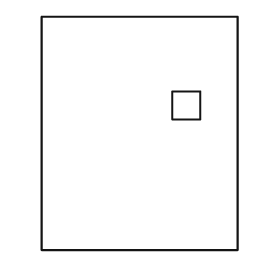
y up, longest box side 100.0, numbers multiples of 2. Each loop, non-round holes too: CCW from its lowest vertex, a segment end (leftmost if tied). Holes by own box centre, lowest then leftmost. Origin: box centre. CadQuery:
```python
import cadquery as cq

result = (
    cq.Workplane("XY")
    .moveTo(-42.0, -50.0)
    .lineTo(42.0, -50.0)
    .lineTo(42.0, 50.0)
    .lineTo(-42.0, 50.0)
    .close()
    .moveTo(14.0, 6.0)
    .lineTo(26.0, 6.0)
    .lineTo(26.0, 18.0)
    .lineTo(14.0, 18.0)
    .close()
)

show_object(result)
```